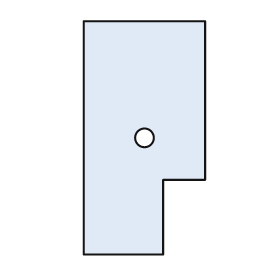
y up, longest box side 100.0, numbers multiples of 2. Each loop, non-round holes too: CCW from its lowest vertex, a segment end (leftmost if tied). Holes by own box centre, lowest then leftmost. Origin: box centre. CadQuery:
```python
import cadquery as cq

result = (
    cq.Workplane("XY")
    .moveTo(-26.0, -50.0)
    .lineTo(8.0, -50.0)
    .lineTo(8.0, -18.0)
    .lineTo(26.0, -18.0)
    .lineTo(26.0, 50.0)
    .lineTo(-26.0, 50.0)
    .close()
    .moveTo(0.0, 0.0)
    .circle(4.0)
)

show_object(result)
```